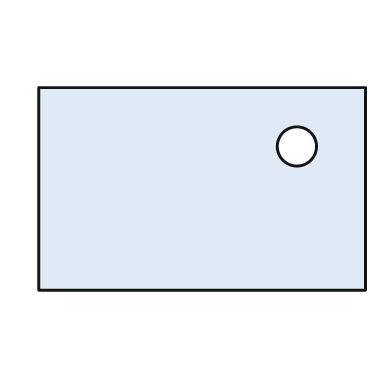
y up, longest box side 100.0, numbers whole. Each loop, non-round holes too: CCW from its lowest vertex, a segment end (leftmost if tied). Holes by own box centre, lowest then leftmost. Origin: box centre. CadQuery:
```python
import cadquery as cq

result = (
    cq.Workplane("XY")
    .moveTo(-50.0, -31.0)
    .lineTo(50.0, -31.0)
    .lineTo(50.0, 31.0)
    .lineTo(-50.0, 31.0)
    .close()
    .moveTo(29.0, 13.0)
    .circle(6.0)
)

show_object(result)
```